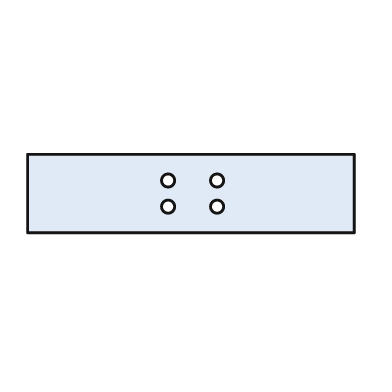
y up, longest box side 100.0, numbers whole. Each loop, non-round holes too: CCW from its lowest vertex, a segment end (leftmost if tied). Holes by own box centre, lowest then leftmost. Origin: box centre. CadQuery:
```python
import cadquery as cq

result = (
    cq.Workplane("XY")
    .moveTo(-50.0, -12.0)
    .lineTo(50.0, -12.0)
    .lineTo(50.0, 12.0)
    .lineTo(-50.0, 12.0)
    .close()
    .moveTo(-7.0, -4.0)
    .circle(2.0)
    .moveTo(8.0, -4.0)
    .circle(2.0)
    .moveTo(-7.0, 4.0)
    .circle(2.0)
    .moveTo(8.0, 4.0)
    .circle(2.0)
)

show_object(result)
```